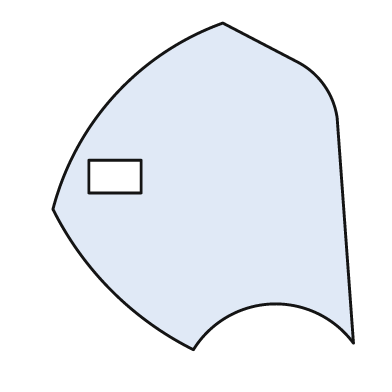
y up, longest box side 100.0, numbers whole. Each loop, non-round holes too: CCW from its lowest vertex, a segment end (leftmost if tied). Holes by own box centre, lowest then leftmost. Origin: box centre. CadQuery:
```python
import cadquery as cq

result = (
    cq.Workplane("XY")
    .moveTo(-3.0, -50.0)
    .threePointArc((21.0, -36.0), (46.0, -48.0))
    .lineTo(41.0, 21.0)
    .threePointArc((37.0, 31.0), (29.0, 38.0))
    .lineTo(6.0, 50.0)
    .threePointArc((-27.0, 28.0), (-46.0, -7.0))
    .threePointArc((-28.0, -32.0), (-3.0, -50.0))
    .close()
    .moveTo(-35.0, -2.0)
    .lineTo(-19.0, -2.0)
    .lineTo(-19.0, 8.0)
    .lineTo(-35.0, 8.0)
    .close()
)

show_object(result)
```